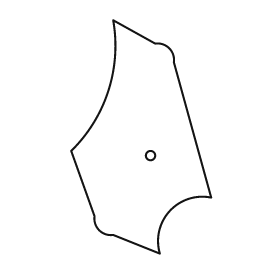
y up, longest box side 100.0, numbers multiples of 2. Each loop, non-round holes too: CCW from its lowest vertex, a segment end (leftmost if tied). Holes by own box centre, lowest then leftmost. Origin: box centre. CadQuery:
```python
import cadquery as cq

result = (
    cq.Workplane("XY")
    .moveTo(8.0, -50.0)
    .threePointArc((12.0, -32.0), (30.0, -26.0))
    .lineTo(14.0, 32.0)
    .threePointArc((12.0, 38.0), (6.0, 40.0))
    .lineTo(-12.0, 50.0)
    .threePointArc((-14.0, 20.0), (-30.0, -6.0))
    .lineTo(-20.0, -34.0)
    .threePointArc((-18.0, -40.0), (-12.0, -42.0))
    .close()
    .moveTo(4.0, -8.0)
    .circle(2.0)
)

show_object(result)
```